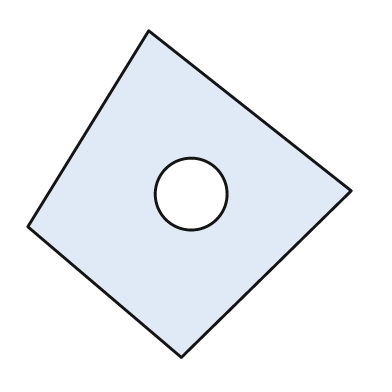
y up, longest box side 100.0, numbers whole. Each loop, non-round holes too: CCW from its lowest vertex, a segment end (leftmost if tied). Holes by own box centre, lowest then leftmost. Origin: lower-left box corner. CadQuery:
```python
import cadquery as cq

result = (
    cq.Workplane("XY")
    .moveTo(47.0, 0.0)
    .lineTo(99.0, 51.0)
    .lineTo(37.0, 100.0)
    .lineTo(0.0, 40.0)
    .close()
    .moveTo(50.0, 50.0)
    .circle(11.0)
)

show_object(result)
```